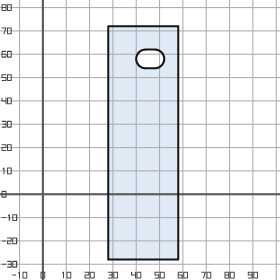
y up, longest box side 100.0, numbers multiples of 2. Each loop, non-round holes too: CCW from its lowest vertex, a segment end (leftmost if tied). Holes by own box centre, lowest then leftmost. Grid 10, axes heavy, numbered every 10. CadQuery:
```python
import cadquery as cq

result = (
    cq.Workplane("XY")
    .moveTo(28.0, -28.0)
    .lineTo(58.0, -28.0)
    .lineTo(58.0, 72.0)
    .lineTo(28.0, 72.0)
    .close()
    .moveTo(44.0, 54.0)
    .lineTo(48.0, 54.0)
    .threePointArc((52.0, 58.0), (48.0, 62.0))
    .lineTo(44.0, 62.0)
    .threePointArc((40.0, 58.0), (44.0, 54.0))
    .close()
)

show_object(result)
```